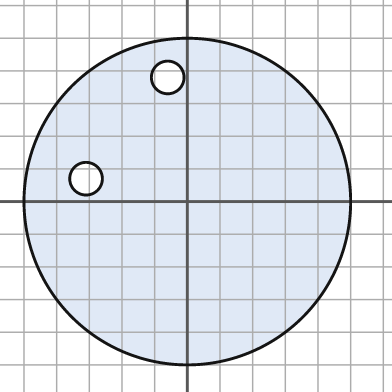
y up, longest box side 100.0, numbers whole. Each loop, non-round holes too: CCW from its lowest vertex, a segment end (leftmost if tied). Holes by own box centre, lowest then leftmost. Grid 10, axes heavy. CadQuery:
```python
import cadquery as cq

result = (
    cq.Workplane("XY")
    .moveTo(0.0, 0.0)
    .circle(50.0)
    .moveTo(-31.0, 7.0)
    .circle(5.0)
    .moveTo(-6.0, 38.0)
    .circle(5.0)
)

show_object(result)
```